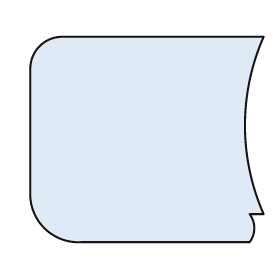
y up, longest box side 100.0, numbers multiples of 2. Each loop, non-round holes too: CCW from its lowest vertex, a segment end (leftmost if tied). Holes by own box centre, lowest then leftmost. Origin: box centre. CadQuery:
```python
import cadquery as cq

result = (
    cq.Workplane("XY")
    .moveTo(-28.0, -44.0)
    .lineTo(44.0, -44.0)
    .threePointArc((46.0, -38.0), (44.0, -32.0))
    .lineTo(50.0, -32.0)
    .threePointArc((42.0, 6.0), (50.0, 44.0))
    .lineTo(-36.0, 44.0)
    .threePointArc((-46.0, 40.0), (-50.0, 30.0))
    .lineTo(-50.0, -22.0)
    .threePointArc((-44.0, -38.0), (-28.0, -44.0))
    .close()
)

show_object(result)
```